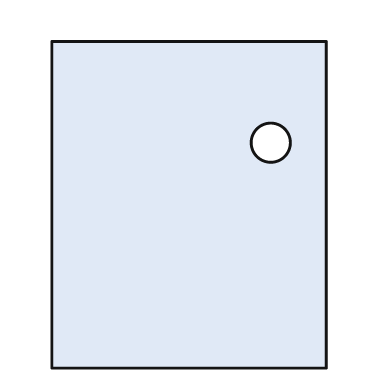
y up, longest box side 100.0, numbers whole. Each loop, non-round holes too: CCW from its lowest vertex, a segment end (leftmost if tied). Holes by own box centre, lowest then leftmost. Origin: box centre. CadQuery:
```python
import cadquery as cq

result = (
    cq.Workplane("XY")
    .moveTo(-42.0, -50.0)
    .lineTo(42.0, -50.0)
    .lineTo(42.0, 50.0)
    .lineTo(-42.0, 50.0)
    .close()
    .moveTo(25.0, 19.0)
    .circle(6.0)
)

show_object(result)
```